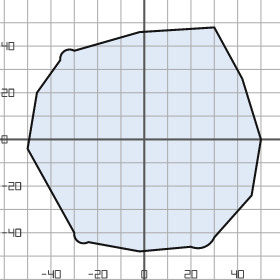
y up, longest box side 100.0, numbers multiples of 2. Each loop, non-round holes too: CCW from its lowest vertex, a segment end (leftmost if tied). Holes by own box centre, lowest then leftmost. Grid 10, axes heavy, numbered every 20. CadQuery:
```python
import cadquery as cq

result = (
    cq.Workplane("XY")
    .moveTo(-2.0, -48.0)
    .lineTo(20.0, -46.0)
    .threePointArc((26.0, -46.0), (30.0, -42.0))
    .lineTo(46.0, -24.0)
    .lineTo(50.0, 0.0)
    .lineTo(42.0, 26.0)
    .lineTo(30.0, 48.0)
    .lineTo(-2.0, 46.0)
    .lineTo(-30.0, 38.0)
    .threePointArc((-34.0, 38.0), (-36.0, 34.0))
    .lineTo(-46.0, 20.0)
    .lineTo(-50.0, -4.0)
    .lineTo(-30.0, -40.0)
    .threePointArc((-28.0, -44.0), (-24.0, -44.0))
    .close()
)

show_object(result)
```